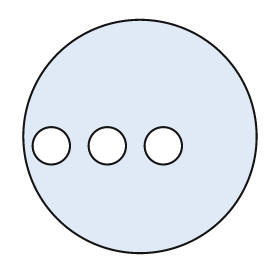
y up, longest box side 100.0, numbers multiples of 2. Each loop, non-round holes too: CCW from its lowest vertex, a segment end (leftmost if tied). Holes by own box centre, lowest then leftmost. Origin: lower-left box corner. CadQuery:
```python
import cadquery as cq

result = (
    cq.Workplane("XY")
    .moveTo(50.0, 50.0)
    .circle(50.0)
    .moveTo(12.0, 46.0)
    .circle(8.0)
    .moveTo(36.0, 46.0)
    .circle(8.0)
    .moveTo(60.0, 46.0)
    .circle(8.0)
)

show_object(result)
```